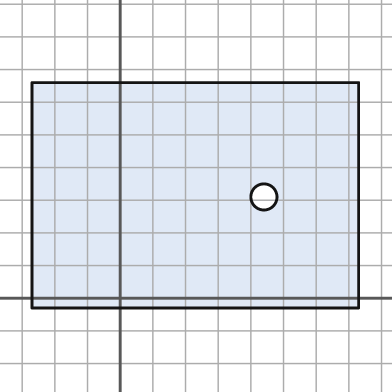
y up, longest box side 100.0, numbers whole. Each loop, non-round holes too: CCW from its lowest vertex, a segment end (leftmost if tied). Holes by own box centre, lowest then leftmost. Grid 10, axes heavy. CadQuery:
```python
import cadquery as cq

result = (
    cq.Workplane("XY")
    .moveTo(-27.0, -3.0)
    .lineTo(73.0, -3.0)
    .lineTo(73.0, 66.0)
    .lineTo(-27.0, 66.0)
    .close()
    .moveTo(44.0, 31.0)
    .circle(4.0)
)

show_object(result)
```